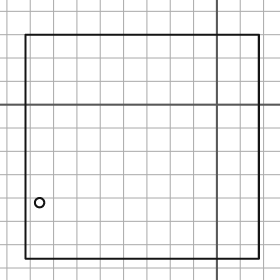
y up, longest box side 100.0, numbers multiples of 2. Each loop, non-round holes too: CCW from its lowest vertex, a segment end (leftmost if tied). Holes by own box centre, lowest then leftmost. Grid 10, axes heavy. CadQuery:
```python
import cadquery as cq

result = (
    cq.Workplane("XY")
    .moveTo(-82.0, -66.0)
    .lineTo(18.0, -66.0)
    .lineTo(18.0, 30.0)
    .lineTo(-82.0, 30.0)
    .close()
    .moveTo(-76.0, -42.0)
    .circle(2.0)
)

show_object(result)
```